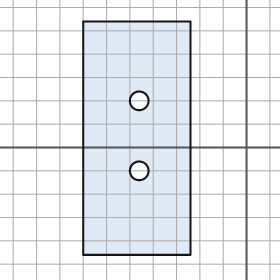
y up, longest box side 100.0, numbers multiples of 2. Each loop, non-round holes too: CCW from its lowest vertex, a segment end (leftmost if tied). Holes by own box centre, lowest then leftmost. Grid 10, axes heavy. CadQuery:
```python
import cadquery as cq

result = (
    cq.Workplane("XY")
    .moveTo(-70.0, -46.0)
    .lineTo(-24.0, -46.0)
    .lineTo(-24.0, 54.0)
    .lineTo(-70.0, 54.0)
    .close()
    .moveTo(-46.0, -10.0)
    .circle(4.0)
    .moveTo(-46.0, 20.0)
    .circle(4.0)
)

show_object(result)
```